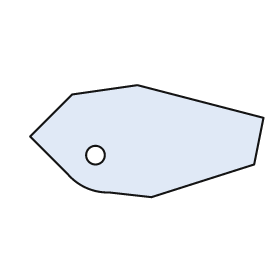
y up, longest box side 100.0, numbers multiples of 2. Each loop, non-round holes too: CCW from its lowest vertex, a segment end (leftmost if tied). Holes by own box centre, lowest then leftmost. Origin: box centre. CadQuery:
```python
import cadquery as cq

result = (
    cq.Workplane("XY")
    .moveTo(2.0, -24.0)
    .lineTo(46.0, -10.0)
    .lineTo(50.0, 10.0)
    .lineTo(-4.0, 24.0)
    .lineTo(-32.0, 20.0)
    .lineTo(-50.0, 2.0)
    .lineTo(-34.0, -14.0)
    .threePointArc((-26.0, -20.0), (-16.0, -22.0))
    .close()
    .moveTo(-22.0, -6.0)
    .circle(4.0)
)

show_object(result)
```